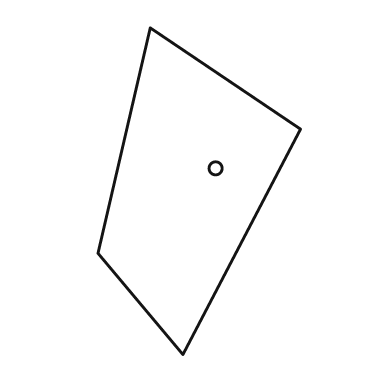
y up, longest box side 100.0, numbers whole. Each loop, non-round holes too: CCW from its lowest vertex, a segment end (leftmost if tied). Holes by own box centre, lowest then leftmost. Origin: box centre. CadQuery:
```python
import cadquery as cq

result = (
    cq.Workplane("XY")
    .moveTo(-5.0, -50.0)
    .lineTo(31.0, 19.0)
    .lineTo(-15.0, 50.0)
    .lineTo(-31.0, -19.0)
    .close()
    .moveTo(5.0, 7.0)
    .circle(2.0)
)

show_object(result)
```